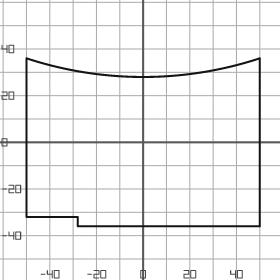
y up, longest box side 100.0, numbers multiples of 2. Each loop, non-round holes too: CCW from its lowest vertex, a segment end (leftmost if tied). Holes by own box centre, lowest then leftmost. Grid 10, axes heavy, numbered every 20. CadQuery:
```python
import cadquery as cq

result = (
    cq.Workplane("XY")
    .moveTo(-28.0, -36.0)
    .lineTo(50.0, -36.0)
    .lineTo(50.0, 36.0)
    .threePointArc((0.0, 28.0), (-50.0, 36.0))
    .lineTo(-50.0, -32.0)
    .lineTo(-28.0, -32.0)
    .close()
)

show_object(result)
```